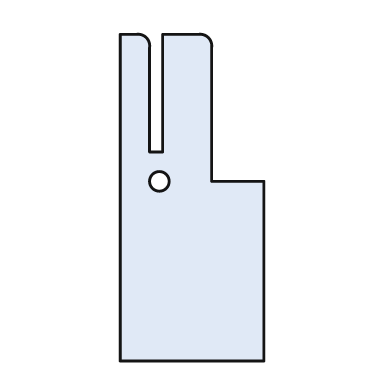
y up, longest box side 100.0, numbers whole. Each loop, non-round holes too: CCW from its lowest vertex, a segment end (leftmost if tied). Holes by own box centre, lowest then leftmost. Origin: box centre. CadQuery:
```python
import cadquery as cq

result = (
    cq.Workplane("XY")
    .moveTo(-22.0, -50.0)
    .lineTo(22.0, -50.0)
    .lineTo(22.0, 5.0)
    .lineTo(6.0, 5.0)
    .lineTo(6.0, 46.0)
    .threePointArc((5.0, 49.0), (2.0, 50.0))
    .lineTo(-9.0, 50.0)
    .lineTo(-9.0, 14.0)
    .lineTo(-13.0, 14.0)
    .lineTo(-13.0, 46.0)
    .threePointArc((-14.0, 49.0), (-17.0, 50.0))
    .lineTo(-22.0, 50.0)
    .close()
    .moveTo(-10.0, 5.0)
    .circle(3.0)
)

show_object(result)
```